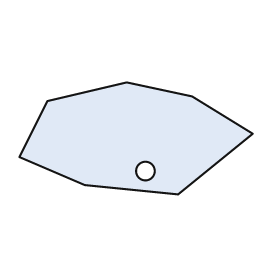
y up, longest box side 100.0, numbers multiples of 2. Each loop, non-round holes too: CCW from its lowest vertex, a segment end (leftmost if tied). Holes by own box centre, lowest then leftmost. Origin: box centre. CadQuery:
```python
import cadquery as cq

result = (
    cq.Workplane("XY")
    .moveTo(18.0, -24.0)
    .lineTo(50.0, 2.0)
    .lineTo(24.0, 18.0)
    .lineTo(-4.0, 24.0)
    .lineTo(-38.0, 16.0)
    .lineTo(-50.0, -8.0)
    .lineTo(-22.0, -20.0)
    .close()
    .moveTo(4.0, -14.0)
    .circle(4.0)
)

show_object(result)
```